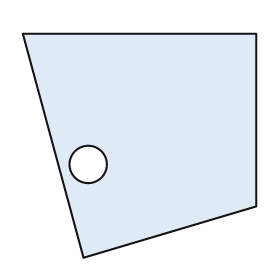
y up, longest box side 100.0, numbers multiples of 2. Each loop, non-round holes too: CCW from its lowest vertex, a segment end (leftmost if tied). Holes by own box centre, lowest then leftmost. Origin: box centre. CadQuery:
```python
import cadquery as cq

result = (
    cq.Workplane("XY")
    .moveTo(-24.0, -48.0)
    .lineTo(50.0, -26.0)
    .lineTo(50.0, 48.0)
    .lineTo(-50.0, 48.0)
    .close()
    .moveTo(-22.0, -8.0)
    .circle(8.0)
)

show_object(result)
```